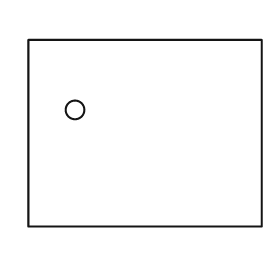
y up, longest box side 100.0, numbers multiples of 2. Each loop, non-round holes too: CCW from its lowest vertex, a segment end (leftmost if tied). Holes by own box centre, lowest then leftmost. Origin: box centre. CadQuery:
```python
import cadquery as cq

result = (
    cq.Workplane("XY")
    .moveTo(-50.0, -40.0)
    .lineTo(50.0, -40.0)
    .lineTo(50.0, 40.0)
    .lineTo(-50.0, 40.0)
    .close()
    .moveTo(-30.0, 10.0)
    .circle(4.0)
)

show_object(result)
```